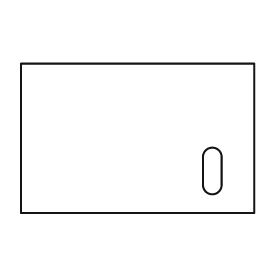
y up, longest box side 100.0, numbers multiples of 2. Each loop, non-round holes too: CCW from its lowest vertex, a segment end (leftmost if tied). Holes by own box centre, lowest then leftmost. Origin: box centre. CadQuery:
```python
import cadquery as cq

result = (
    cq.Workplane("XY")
    .moveTo(-50.0, -32.0)
    .lineTo(50.0, -32.0)
    .lineTo(50.0, 32.0)
    .lineTo(-50.0, 32.0)
    .close()
    .moveTo(28.0, -20.0)
    .threePointArc((32.0, -24.0), (36.0, -20.0))
    .lineTo(36.0, -8.0)
    .threePointArc((32.0, -4.0), (28.0, -8.0))
    .close()
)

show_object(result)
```